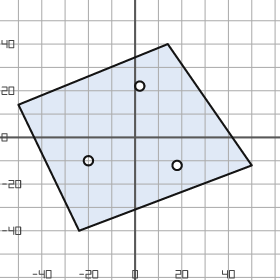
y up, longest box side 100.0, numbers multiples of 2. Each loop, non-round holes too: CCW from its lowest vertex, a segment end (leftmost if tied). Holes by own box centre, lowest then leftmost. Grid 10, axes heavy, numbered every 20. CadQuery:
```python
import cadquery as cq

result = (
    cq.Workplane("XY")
    .moveTo(-24.0, -40.0)
    .lineTo(50.0, -12.0)
    .lineTo(14.0, 40.0)
    .lineTo(-50.0, 14.0)
    .close()
    .moveTo(18.0, -12.0)
    .circle(2.0)
    .moveTo(-20.0, -10.0)
    .circle(2.0)
    .moveTo(2.0, 22.0)
    .circle(2.0)
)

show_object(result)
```